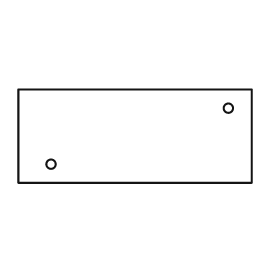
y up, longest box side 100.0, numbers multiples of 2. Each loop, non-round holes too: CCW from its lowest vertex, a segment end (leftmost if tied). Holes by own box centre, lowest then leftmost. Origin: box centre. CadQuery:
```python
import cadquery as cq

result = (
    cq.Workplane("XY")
    .moveTo(-50.0, -20.0)
    .lineTo(50.0, -20.0)
    .lineTo(50.0, 20.0)
    .lineTo(-50.0, 20.0)
    .close()
    .moveTo(-36.0, -12.0)
    .circle(2.0)
    .moveTo(40.0, 12.0)
    .circle(2.0)
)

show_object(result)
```